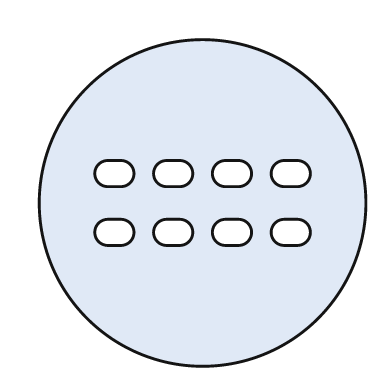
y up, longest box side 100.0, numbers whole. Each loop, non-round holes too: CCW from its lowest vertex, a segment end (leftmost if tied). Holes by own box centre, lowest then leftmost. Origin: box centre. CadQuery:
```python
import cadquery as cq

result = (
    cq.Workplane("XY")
    .moveTo(0.0, 0.0)
    .circle(50.0)
    .moveTo(-29.0, -13.0)
    .lineTo(-25.0, -13.0)
    .threePointArc((-21.0, -9.0), (-25.0, -5.0))
    .lineTo(-29.0, -5.0)
    .threePointArc((-33.0, -9.0), (-29.0, -13.0))
    .close()
    .moveTo(-11.0, -13.0)
    .lineTo(-7.0, -13.0)
    .threePointArc((-3.0, -9.0), (-7.0, -5.0))
    .lineTo(-11.0, -5.0)
    .threePointArc((-15.0, -9.0), (-11.0, -13.0))
    .close()
    .moveTo(7.0, -13.0)
    .lineTo(11.0, -13.0)
    .threePointArc((15.0, -9.0), (11.0, -5.0))
    .lineTo(7.0, -5.0)
    .threePointArc((3.0, -9.0), (7.0, -13.0))
    .close()
    .moveTo(25.0, -13.0)
    .lineTo(29.0, -13.0)
    .threePointArc((33.0, -9.0), (29.0, -5.0))
    .lineTo(25.0, -5.0)
    .threePointArc((21.0, -9.0), (25.0, -13.0))
    .close()
    .moveTo(-29.0, 5.0)
    .lineTo(-25.0, 5.0)
    .threePointArc((-21.0, 9.0), (-25.0, 13.0))
    .lineTo(-29.0, 13.0)
    .threePointArc((-33.0, 9.0), (-29.0, 5.0))
    .close()
    .moveTo(-11.0, 5.0)
    .lineTo(-7.0, 5.0)
    .threePointArc((-3.0, 9.0), (-7.0, 13.0))
    .lineTo(-11.0, 13.0)
    .threePointArc((-15.0, 9.0), (-11.0, 5.0))
    .close()
    .moveTo(7.0, 5.0)
    .lineTo(11.0, 5.0)
    .threePointArc((15.0, 9.0), (11.0, 13.0))
    .lineTo(7.0, 13.0)
    .threePointArc((3.0, 9.0), (7.0, 5.0))
    .close()
    .moveTo(25.0, 5.0)
    .lineTo(29.0, 5.0)
    .threePointArc((33.0, 9.0), (29.0, 13.0))
    .lineTo(25.0, 13.0)
    .threePointArc((21.0, 9.0), (25.0, 5.0))
    .close()
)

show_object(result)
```